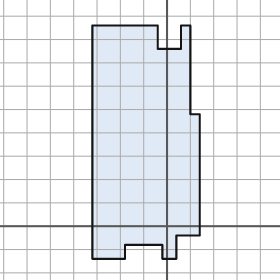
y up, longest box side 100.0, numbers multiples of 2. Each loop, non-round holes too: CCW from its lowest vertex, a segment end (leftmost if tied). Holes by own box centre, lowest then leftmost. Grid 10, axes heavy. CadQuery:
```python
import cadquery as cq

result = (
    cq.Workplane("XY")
    .moveTo(-32.0, -14.0)
    .lineTo(-18.0, -14.0)
    .lineTo(-18.0, -8.0)
    .lineTo(-2.0, -8.0)
    .lineTo(-2.0, -14.0)
    .lineTo(4.0, -14.0)
    .lineTo(4.0, -4.0)
    .lineTo(14.0, -4.0)
    .lineTo(14.0, 48.0)
    .lineTo(10.0, 48.0)
    .lineTo(10.0, 86.0)
    .lineTo(6.0, 86.0)
    .lineTo(6.0, 76.0)
    .lineTo(-4.0, 76.0)
    .lineTo(-4.0, 86.0)
    .lineTo(-32.0, 86.0)
    .close()
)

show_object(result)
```